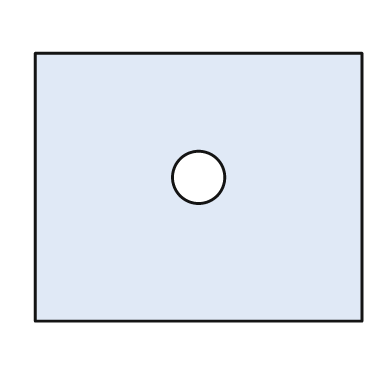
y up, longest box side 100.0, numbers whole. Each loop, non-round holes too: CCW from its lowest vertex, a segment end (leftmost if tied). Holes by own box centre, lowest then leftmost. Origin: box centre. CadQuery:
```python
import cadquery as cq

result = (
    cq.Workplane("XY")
    .moveTo(-50.0, -41.0)
    .lineTo(50.0, -41.0)
    .lineTo(50.0, 41.0)
    .lineTo(-50.0, 41.0)
    .close()
    .moveTo(0.0, 3.0)
    .circle(8.0)
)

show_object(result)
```